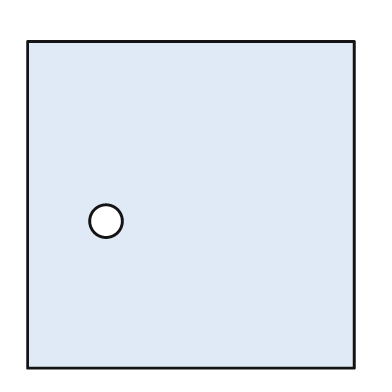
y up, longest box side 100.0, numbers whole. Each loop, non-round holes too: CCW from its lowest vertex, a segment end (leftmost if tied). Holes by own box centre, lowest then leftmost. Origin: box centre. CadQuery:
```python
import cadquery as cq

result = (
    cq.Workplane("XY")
    .moveTo(-50.0, -50.0)
    .lineTo(50.0, -50.0)
    .lineTo(50.0, 50.0)
    .lineTo(-50.0, 50.0)
    .close()
    .moveTo(-26.0, -5.0)
    .circle(5.0)
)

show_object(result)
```